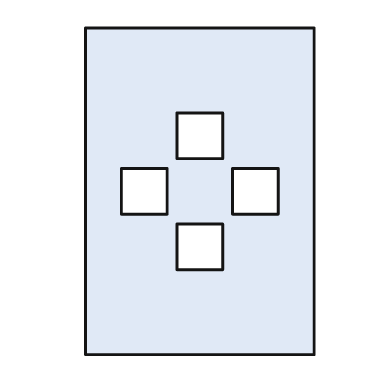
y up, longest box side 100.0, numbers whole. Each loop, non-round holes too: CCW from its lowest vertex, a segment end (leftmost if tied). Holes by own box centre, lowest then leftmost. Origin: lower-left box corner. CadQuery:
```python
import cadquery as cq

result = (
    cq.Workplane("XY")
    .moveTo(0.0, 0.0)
    .lineTo(70.0, 0.0)
    .lineTo(70.0, 100.0)
    .lineTo(0.0, 100.0)
    .close()
    .moveTo(28.0, 26.0)
    .lineTo(42.0, 26.0)
    .lineTo(42.0, 40.0)
    .lineTo(28.0, 40.0)
    .close()
    .moveTo(11.0, 43.0)
    .lineTo(25.0, 43.0)
    .lineTo(25.0, 57.0)
    .lineTo(11.0, 57.0)
    .close()
    .moveTo(45.0, 43.0)
    .lineTo(59.0, 43.0)
    .lineTo(59.0, 57.0)
    .lineTo(45.0, 57.0)
    .close()
    .moveTo(28.0, 60.0)
    .lineTo(42.0, 60.0)
    .lineTo(42.0, 74.0)
    .lineTo(28.0, 74.0)
    .close()
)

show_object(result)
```